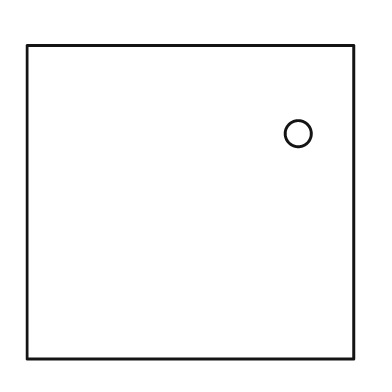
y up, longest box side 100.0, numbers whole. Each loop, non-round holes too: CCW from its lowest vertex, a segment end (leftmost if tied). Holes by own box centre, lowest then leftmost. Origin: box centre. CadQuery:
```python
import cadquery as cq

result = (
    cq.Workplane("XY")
    .moveTo(-50.0, -48.0)
    .lineTo(50.0, -48.0)
    .lineTo(50.0, 48.0)
    .lineTo(-50.0, 48.0)
    .close()
    .moveTo(33.0, 21.0)
    .circle(4.0)
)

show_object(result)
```